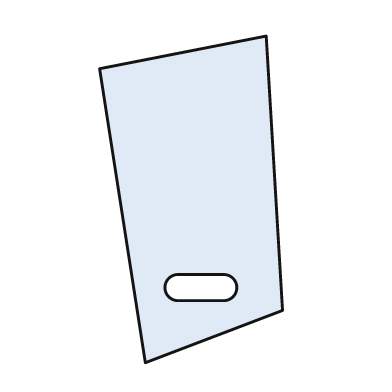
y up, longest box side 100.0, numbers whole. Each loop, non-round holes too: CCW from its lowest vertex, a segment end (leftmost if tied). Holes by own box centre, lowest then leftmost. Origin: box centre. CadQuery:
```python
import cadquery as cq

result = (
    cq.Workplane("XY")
    .moveTo(-14.0, -50.0)
    .lineTo(28.0, -34.0)
    .lineTo(23.0, 50.0)
    .lineTo(-28.0, 40.0)
    .close()
    .moveTo(-4.0, -31.0)
    .lineTo(10.0, -31.0)
    .threePointArc((14.0, -27.0), (10.0, -23.0))
    .lineTo(-4.0, -23.0)
    .threePointArc((-8.0, -27.0), (-4.0, -31.0))
    .close()
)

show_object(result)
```